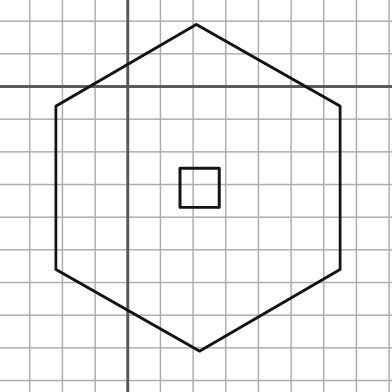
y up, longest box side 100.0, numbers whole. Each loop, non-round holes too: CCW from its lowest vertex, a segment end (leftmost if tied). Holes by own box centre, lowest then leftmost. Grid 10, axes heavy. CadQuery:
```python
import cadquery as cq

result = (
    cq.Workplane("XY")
    .moveTo(22.0, -81.0)
    .lineTo(65.0, -56.0)
    .lineTo(65.0, -6.0)
    .lineTo(21.0, 19.0)
    .lineTo(-22.0, -6.0)
    .lineTo(-22.0, -56.0)
    .close()
    .moveTo(16.0, -37.0)
    .lineTo(28.0, -37.0)
    .lineTo(28.0, -25.0)
    .lineTo(16.0, -25.0)
    .close()
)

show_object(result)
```